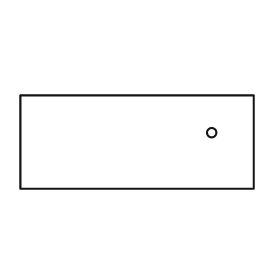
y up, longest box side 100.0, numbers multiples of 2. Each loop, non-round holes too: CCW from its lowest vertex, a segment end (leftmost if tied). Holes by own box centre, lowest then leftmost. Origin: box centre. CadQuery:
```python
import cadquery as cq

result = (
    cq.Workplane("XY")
    .moveTo(-50.0, -20.0)
    .lineTo(50.0, -20.0)
    .lineTo(50.0, 20.0)
    .lineTo(-50.0, 20.0)
    .close()
    .moveTo(32.0, 4.0)
    .circle(2.0)
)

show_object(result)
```